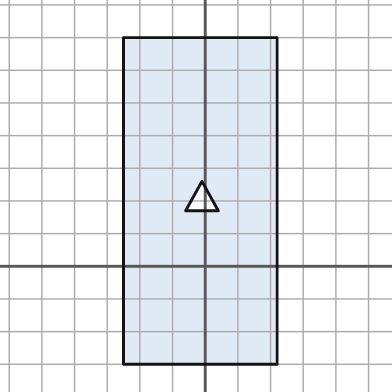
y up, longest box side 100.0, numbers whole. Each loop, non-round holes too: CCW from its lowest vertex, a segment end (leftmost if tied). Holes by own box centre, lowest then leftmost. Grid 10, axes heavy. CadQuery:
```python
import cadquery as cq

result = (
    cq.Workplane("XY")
    .moveTo(-25.0, -30.0)
    .lineTo(22.0, -30.0)
    .lineTo(22.0, 70.0)
    .lineTo(-25.0, 70.0)
    .close()
    .moveTo(-6.0, 17.0)
    .lineTo(4.0, 17.0)
    .lineTo(-1.0, 26.0)
    .close()
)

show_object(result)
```